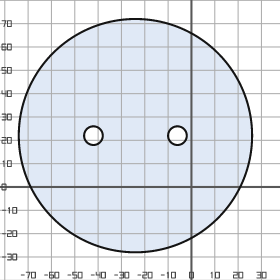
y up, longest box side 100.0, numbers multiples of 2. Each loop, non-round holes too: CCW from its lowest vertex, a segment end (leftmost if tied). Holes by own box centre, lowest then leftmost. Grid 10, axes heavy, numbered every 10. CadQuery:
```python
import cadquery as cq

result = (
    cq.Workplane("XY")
    .moveTo(-24.0, 22.0)
    .circle(50.0)
    .moveTo(-42.0, 22.0)
    .circle(4.0)
    .moveTo(-6.0, 22.0)
    .circle(4.0)
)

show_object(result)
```